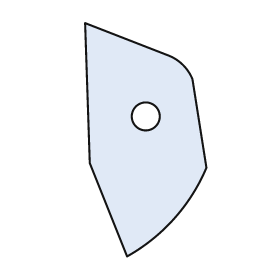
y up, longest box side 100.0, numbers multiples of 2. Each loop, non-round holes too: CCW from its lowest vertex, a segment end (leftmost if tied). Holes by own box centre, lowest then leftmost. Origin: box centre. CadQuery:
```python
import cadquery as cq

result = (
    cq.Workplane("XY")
    .moveTo(-8.0, -50.0)
    .threePointArc((12.0, -34.0), (26.0, -12.0))
    .lineTo(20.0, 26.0)
    .threePointArc((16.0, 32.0), (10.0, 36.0))
    .lineTo(-26.0, 50.0)
    .lineTo(-24.0, -10.0)
    .close()
    .moveTo(0.0, 10.0)
    .circle(6.0)
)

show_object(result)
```